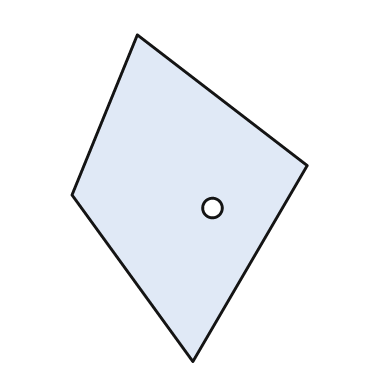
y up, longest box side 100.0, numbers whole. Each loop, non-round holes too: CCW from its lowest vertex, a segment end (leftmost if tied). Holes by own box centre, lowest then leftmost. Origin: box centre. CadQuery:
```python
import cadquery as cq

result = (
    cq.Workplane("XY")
    .moveTo(1.0, -50.0)
    .lineTo(36.0, 10.0)
    .lineTo(-16.0, 50.0)
    .lineTo(-36.0, 1.0)
    .close()
    .moveTo(7.0, -3.0)
    .circle(3.0)
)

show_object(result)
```